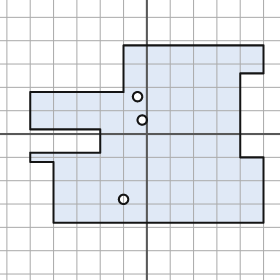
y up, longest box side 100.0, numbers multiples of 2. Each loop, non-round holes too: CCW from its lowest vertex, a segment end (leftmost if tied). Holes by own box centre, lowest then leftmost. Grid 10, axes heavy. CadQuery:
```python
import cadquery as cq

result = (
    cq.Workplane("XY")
    .moveTo(-40.0, -38.0)
    .lineTo(50.0, -38.0)
    .lineTo(50.0, -10.0)
    .lineTo(40.0, -10.0)
    .lineTo(40.0, 26.0)
    .lineTo(50.0, 26.0)
    .lineTo(50.0, 38.0)
    .lineTo(-10.0, 38.0)
    .lineTo(-10.0, 18.0)
    .lineTo(-50.0, 18.0)
    .lineTo(-50.0, 2.0)
    .lineTo(-20.0, 2.0)
    .lineTo(-20.0, -8.0)
    .lineTo(-50.0, -8.0)
    .lineTo(-50.0, -12.0)
    .lineTo(-40.0, -12.0)
    .close()
    .moveTo(-10.0, -28.0)
    .circle(2.0)
    .moveTo(-2.0, 6.0)
    .circle(2.0)
    .moveTo(-4.0, 16.0)
    .circle(2.0)
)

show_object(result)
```